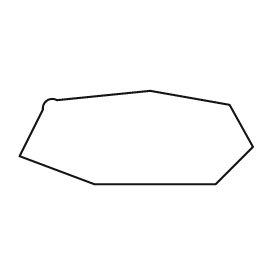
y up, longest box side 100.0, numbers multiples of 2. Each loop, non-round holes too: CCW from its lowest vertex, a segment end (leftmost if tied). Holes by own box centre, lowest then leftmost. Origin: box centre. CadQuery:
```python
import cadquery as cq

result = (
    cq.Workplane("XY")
    .moveTo(-18.0, -20.0)
    .lineTo(34.0, -20.0)
    .lineTo(50.0, -4.0)
    .lineTo(40.0, 14.0)
    .lineTo(6.0, 20.0)
    .lineTo(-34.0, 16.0)
    .threePointArc((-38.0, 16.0), (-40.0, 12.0))
    .lineTo(-50.0, -8.0)
    .close()
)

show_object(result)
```